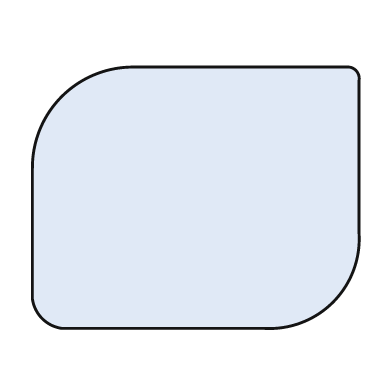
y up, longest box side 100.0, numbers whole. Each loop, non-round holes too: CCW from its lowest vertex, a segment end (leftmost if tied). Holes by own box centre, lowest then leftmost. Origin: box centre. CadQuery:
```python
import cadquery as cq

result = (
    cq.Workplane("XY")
    .moveTo(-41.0, -40.0)
    .lineTo(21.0, -40.0)
    .threePointArc((42.0, -32.0), (50.0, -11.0))
    .lineTo(50.0, 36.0)
    .threePointArc((49.0, 39.0), (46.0, 40.0))
    .lineTo(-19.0, 40.0)
    .threePointArc((-41.0, 31.0), (-50.0, 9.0))
    .lineTo(-50.0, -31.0)
    .threePointArc((-47.0, -37.0), (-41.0, -40.0))
    .close()
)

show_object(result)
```